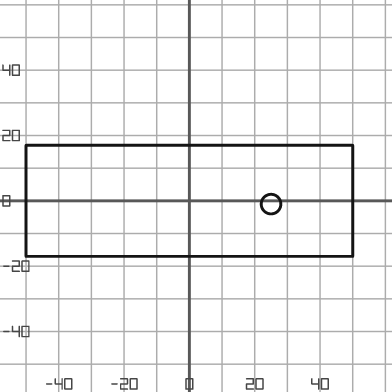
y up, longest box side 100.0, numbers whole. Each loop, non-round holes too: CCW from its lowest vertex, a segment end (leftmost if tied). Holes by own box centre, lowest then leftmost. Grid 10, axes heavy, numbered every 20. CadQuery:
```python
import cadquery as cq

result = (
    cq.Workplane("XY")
    .moveTo(-50.0, -17.0)
    .lineTo(50.0, -17.0)
    .lineTo(50.0, 17.0)
    .lineTo(-50.0, 17.0)
    .close()
    .moveTo(25.0, -1.0)
    .circle(3.0)
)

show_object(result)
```